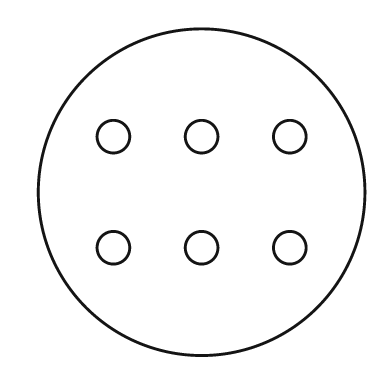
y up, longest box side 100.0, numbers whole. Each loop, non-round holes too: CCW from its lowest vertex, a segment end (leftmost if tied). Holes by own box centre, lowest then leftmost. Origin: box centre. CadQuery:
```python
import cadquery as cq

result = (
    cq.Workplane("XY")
    .moveTo(0.0, 0.0)
    .circle(50.0)
    .moveTo(-27.0, -17.0)
    .circle(5.0)
    .moveTo(0.0, -17.0)
    .circle(5.0)
    .moveTo(27.0, -17.0)
    .circle(5.0)
    .moveTo(-27.0, 17.0)
    .circle(5.0)
    .moveTo(0.0, 17.0)
    .circle(5.0)
    .moveTo(27.0, 17.0)
    .circle(5.0)
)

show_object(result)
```